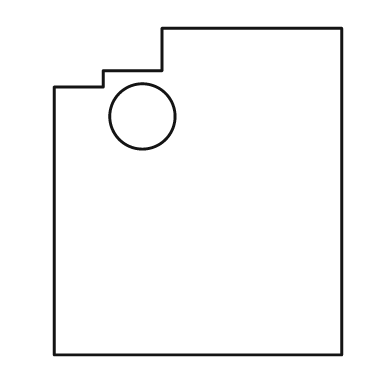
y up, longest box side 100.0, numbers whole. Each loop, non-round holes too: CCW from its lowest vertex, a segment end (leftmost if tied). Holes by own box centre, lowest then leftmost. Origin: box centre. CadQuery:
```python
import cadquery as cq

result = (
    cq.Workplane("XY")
    .moveTo(-44.0, -50.0)
    .lineTo(44.0, -50.0)
    .lineTo(44.0, 50.0)
    .lineTo(-11.0, 50.0)
    .lineTo(-11.0, 37.0)
    .lineTo(-29.0, 37.0)
    .lineTo(-29.0, 32.0)
    .lineTo(-44.0, 32.0)
    .close()
    .moveTo(-17.0, 23.0)
    .circle(10.0)
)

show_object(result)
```